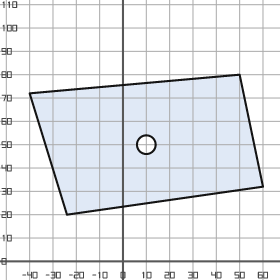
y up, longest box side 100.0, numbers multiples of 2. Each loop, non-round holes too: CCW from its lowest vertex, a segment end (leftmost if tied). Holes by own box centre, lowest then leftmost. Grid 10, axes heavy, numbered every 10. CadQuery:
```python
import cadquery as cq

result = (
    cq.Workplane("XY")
    .moveTo(-24.0, 20.0)
    .lineTo(60.0, 32.0)
    .lineTo(50.0, 80.0)
    .lineTo(-40.0, 72.0)
    .close()
    .moveTo(10.0, 50.0)
    .circle(4.0)
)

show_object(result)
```